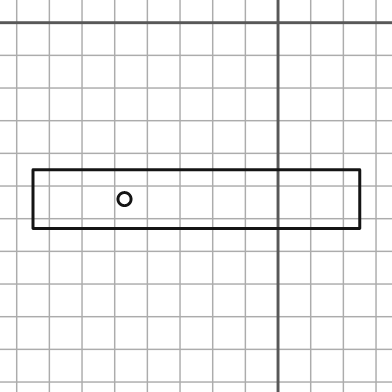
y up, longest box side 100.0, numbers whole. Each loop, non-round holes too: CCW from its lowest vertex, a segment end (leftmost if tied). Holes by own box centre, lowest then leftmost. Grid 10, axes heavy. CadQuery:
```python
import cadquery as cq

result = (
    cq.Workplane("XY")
    .moveTo(-75.0, -63.0)
    .lineTo(25.0, -63.0)
    .lineTo(25.0, -45.0)
    .lineTo(-75.0, -45.0)
    .close()
    .moveTo(-47.0, -54.0)
    .circle(2.0)
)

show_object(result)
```